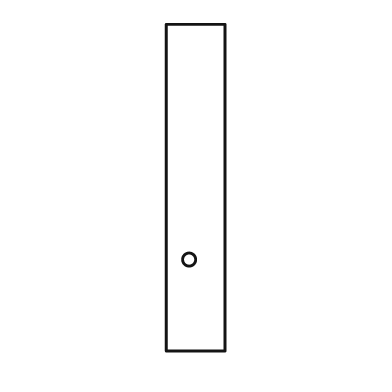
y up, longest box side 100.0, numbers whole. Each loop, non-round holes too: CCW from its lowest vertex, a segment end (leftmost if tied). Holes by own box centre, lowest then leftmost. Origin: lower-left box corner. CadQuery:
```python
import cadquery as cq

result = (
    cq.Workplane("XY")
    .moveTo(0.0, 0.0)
    .lineTo(18.0, 0.0)
    .lineTo(18.0, 100.0)
    .lineTo(0.0, 100.0)
    .close()
    .moveTo(7.0, 28.0)
    .circle(2.0)
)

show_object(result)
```